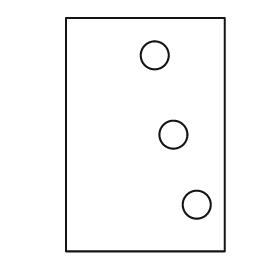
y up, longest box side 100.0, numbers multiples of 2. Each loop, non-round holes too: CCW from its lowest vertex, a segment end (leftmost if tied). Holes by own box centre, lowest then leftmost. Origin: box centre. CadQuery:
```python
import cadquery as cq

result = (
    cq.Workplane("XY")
    .moveTo(-34.0, -50.0)
    .lineTo(34.0, -50.0)
    .lineTo(34.0, 50.0)
    .lineTo(-34.0, 50.0)
    .close()
    .moveTo(22.0, -30.0)
    .circle(6.0)
    .moveTo(12.0, 0.0)
    .circle(6.0)
    .moveTo(4.0, 34.0)
    .circle(6.0)
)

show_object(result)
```